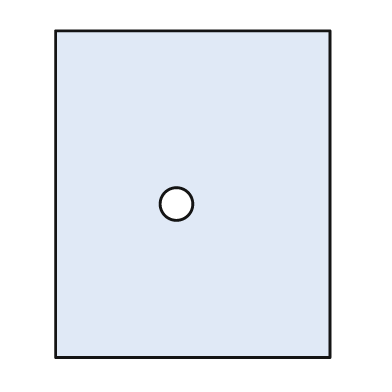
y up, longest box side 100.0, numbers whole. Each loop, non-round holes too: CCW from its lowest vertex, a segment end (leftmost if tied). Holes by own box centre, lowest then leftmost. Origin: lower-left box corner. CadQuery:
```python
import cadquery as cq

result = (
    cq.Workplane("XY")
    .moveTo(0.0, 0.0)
    .lineTo(84.0, 0.0)
    .lineTo(84.0, 100.0)
    .lineTo(0.0, 100.0)
    .close()
    .moveTo(37.0, 47.0)
    .circle(5.0)
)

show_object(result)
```